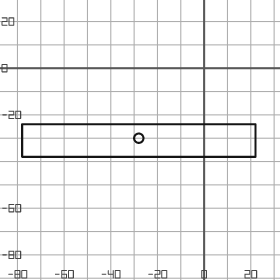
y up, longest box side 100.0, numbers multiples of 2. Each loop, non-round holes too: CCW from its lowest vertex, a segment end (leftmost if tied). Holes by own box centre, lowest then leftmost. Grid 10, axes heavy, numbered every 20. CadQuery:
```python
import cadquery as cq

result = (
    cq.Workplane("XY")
    .moveTo(-78.0, -38.0)
    .lineTo(22.0, -38.0)
    .lineTo(22.0, -24.0)
    .lineTo(-78.0, -24.0)
    .close()
    .moveTo(-28.0, -30.0)
    .circle(2.0)
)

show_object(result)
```